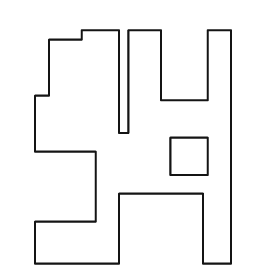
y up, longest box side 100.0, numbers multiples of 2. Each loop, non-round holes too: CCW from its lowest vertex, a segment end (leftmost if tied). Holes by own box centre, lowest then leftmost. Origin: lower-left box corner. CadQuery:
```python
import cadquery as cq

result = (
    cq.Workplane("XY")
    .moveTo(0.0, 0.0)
    .lineTo(36.0, 0.0)
    .lineTo(36.0, 30.0)
    .lineTo(72.0, 30.0)
    .lineTo(72.0, 0.0)
    .lineTo(84.0, 0.0)
    .lineTo(84.0, 100.0)
    .lineTo(74.0, 100.0)
    .lineTo(74.0, 70.0)
    .lineTo(54.0, 70.0)
    .lineTo(54.0, 100.0)
    .lineTo(40.0, 100.0)
    .lineTo(40.0, 56.0)
    .lineTo(36.0, 56.0)
    .lineTo(36.0, 100.0)
    .lineTo(20.0, 100.0)
    .lineTo(20.0, 96.0)
    .lineTo(6.0, 96.0)
    .lineTo(6.0, 72.0)
    .lineTo(0.0, 72.0)
    .lineTo(0.0, 48.0)
    .lineTo(26.0, 48.0)
    .lineTo(26.0, 18.0)
    .lineTo(0.0, 18.0)
    .close()
    .moveTo(58.0, 38.0)
    .lineTo(74.0, 38.0)
    .lineTo(74.0, 54.0)
    .lineTo(58.0, 54.0)
    .close()
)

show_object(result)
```